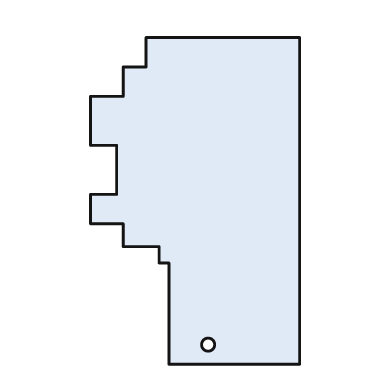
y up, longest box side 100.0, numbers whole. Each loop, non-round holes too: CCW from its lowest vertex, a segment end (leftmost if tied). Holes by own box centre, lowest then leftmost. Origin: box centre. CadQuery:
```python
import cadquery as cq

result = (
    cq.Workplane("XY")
    .moveTo(-8.0, -50.0)
    .lineTo(32.0, -50.0)
    .lineTo(32.0, 50.0)
    .lineTo(-15.0, 50.0)
    .lineTo(-15.0, 41.0)
    .lineTo(-22.0, 41.0)
    .lineTo(-22.0, 32.0)
    .lineTo(-32.0, 32.0)
    .lineTo(-32.0, 17.0)
    .lineTo(-24.0, 17.0)
    .lineTo(-24.0, 2.0)
    .lineTo(-32.0, 2.0)
    .lineTo(-32.0, -7.0)
    .lineTo(-22.0, -7.0)
    .lineTo(-22.0, -14.0)
    .lineTo(-11.0, -14.0)
    .lineTo(-11.0, -19.0)
    .lineTo(-8.0, -19.0)
    .close()
    .moveTo(4.0, -44.0)
    .circle(2.0)
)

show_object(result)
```